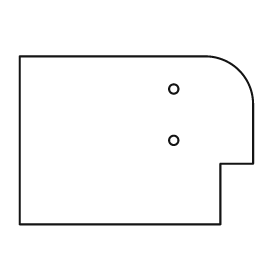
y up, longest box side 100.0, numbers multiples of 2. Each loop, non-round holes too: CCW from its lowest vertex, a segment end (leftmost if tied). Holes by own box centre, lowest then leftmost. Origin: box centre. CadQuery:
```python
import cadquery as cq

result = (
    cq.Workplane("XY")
    .moveTo(-50.0, -36.0)
    .lineTo(36.0, -36.0)
    .lineTo(36.0, -10.0)
    .lineTo(50.0, -10.0)
    .lineTo(50.0, 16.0)
    .threePointArc((44.0, 30.0), (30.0, 36.0))
    .lineTo(-50.0, 36.0)
    .close()
    .moveTo(16.0, 0.0)
    .circle(2.0)
    .moveTo(16.0, 22.0)
    .circle(2.0)
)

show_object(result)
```